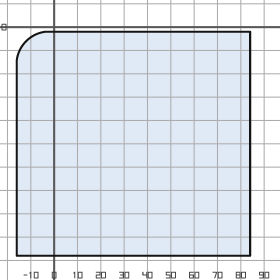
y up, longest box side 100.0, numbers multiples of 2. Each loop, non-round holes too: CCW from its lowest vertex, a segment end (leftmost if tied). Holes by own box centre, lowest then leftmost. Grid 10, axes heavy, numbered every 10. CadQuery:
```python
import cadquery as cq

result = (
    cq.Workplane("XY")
    .moveTo(-16.0, -98.0)
    .lineTo(84.0, -98.0)
    .lineTo(84.0, -2.0)
    .lineTo(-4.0, -2.0)
    .threePointArc((-12.0, -6.0), (-16.0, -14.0))
    .close()
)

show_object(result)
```